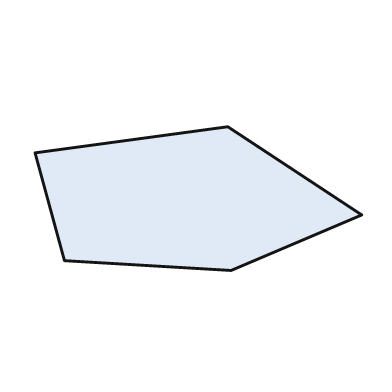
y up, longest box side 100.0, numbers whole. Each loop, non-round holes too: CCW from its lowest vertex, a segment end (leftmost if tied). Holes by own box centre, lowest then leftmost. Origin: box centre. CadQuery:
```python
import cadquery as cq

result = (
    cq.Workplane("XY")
    .moveTo(10.0, -22.0)
    .lineTo(50.0, -5.0)
    .lineTo(9.0, 22.0)
    .lineTo(-50.0, 14.0)
    .lineTo(-41.0, -19.0)
    .close()
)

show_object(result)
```